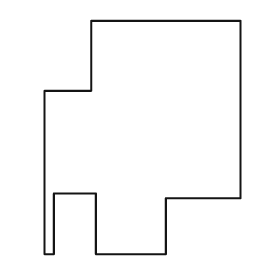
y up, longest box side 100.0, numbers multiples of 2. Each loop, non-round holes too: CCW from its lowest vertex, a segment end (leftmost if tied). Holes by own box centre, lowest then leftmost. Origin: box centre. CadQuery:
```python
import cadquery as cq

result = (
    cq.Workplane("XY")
    .moveTo(-42.0, -50.0)
    .lineTo(-38.0, -50.0)
    .lineTo(-38.0, -24.0)
    .lineTo(-20.0, -24.0)
    .lineTo(-20.0, -50.0)
    .lineTo(10.0, -50.0)
    .lineTo(10.0, -26.0)
    .lineTo(42.0, -26.0)
    .lineTo(42.0, 50.0)
    .lineTo(-22.0, 50.0)
    .lineTo(-22.0, 20.0)
    .lineTo(-42.0, 20.0)
    .close()
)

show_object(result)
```